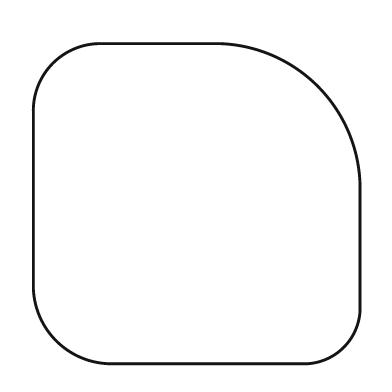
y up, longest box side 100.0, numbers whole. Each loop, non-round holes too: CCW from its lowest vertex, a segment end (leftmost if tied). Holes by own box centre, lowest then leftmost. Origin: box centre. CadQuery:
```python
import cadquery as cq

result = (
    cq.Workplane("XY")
    .moveTo(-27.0, -49.0)
    .lineTo(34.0, -49.0)
    .threePointArc((45.0, -44.0), (50.0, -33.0))
    .lineTo(50.0, 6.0)
    .threePointArc((37.0, 36.0), (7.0, 49.0))
    .lineTo(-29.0, 49.0)
    .threePointArc((-44.0, 43.0), (-50.0, 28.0))
    .lineTo(-50.0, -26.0)
    .threePointArc((-43.0, -42.0), (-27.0, -49.0))
    .close()
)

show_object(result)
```